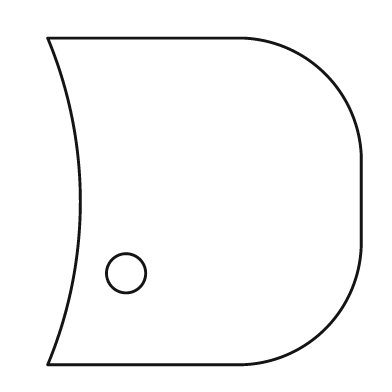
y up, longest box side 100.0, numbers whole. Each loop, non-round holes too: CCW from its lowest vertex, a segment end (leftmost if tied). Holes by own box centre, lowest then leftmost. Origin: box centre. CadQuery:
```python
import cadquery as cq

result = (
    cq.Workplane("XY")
    .moveTo(-48.0, -50.0)
    .lineTo(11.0, -50.0)
    .threePointArc((37.0, -39.0), (48.0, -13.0))
    .lineTo(48.0, 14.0)
    .threePointArc((37.0, 39.0), (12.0, 50.0))
    .lineTo(-48.0, 50.0)
    .threePointArc((-38.0, 0.0), (-48.0, -50.0))
    .close()
    .moveTo(-24.0, -22.0)
    .circle(6.0)
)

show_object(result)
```